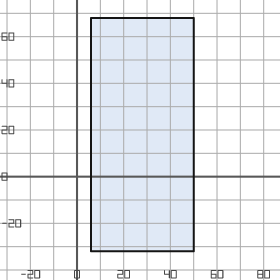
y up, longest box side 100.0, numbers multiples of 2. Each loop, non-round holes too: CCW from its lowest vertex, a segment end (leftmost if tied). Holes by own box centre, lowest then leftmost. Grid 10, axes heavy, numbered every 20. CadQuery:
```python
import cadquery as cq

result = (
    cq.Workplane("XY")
    .moveTo(6.0, -32.0)
    .lineTo(50.0, -32.0)
    .lineTo(50.0, 68.0)
    .lineTo(6.0, 68.0)
    .close()
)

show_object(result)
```